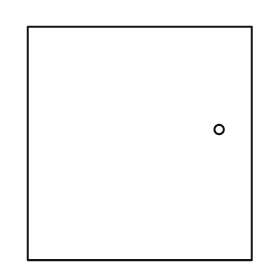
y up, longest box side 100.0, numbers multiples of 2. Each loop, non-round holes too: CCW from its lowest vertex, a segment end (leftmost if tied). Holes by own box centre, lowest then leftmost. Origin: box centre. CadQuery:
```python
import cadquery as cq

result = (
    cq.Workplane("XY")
    .moveTo(-48.0, -50.0)
    .lineTo(48.0, -50.0)
    .lineTo(48.0, 50.0)
    .lineTo(-48.0, 50.0)
    .close()
    .moveTo(34.0, 6.0)
    .circle(2.0)
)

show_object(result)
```